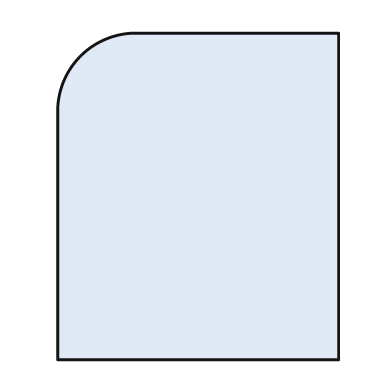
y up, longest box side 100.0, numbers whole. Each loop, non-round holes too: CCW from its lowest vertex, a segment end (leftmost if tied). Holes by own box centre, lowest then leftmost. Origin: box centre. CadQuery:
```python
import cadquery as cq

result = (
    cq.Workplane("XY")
    .moveTo(-43.0, -50.0)
    .lineTo(43.0, -50.0)
    .lineTo(43.0, 50.0)
    .lineTo(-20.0, 50.0)
    .threePointArc((-36.0, 43.0), (-43.0, 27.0))
    .close()
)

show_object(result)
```